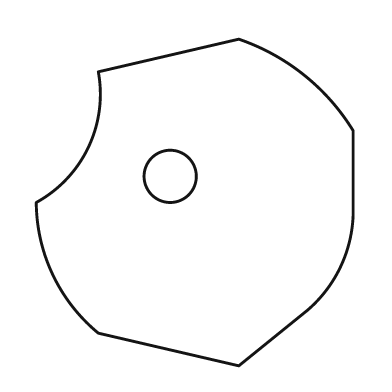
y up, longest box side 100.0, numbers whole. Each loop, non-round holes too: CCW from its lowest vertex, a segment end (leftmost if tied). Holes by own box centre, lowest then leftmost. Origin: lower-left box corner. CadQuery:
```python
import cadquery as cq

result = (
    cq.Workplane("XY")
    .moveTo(62.0, 0.0)
    .lineTo(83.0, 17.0)
    .threePointArc((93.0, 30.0), (97.0, 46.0))
    .lineTo(97.0, 72.0)
    .threePointArc((82.0, 89.0), (62.0, 100.0))
    .lineTo(19.0, 90.0)
    .threePointArc((16.0, 67.0), (0.0, 50.0))
    .threePointArc((5.0, 28.0), (19.0, 10.0))
    .close()
    .moveTo(41.0, 58.0)
    .circle(8.0)
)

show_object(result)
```